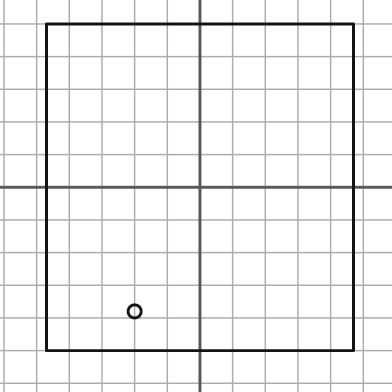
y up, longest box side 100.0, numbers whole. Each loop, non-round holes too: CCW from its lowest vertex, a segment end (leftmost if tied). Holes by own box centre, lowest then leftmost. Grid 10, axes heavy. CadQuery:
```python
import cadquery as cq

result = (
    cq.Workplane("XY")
    .moveTo(-47.0, -50.0)
    .lineTo(47.0, -50.0)
    .lineTo(47.0, 50.0)
    .lineTo(-47.0, 50.0)
    .close()
    .moveTo(-20.0, -38.0)
    .circle(2.0)
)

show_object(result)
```